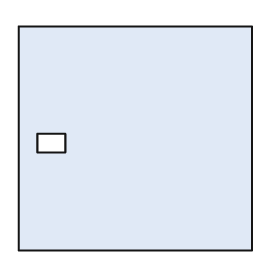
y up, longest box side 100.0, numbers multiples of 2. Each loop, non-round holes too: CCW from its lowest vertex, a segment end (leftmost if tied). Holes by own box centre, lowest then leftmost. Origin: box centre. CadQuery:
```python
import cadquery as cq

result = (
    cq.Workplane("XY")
    .moveTo(-50.0, -48.0)
    .lineTo(50.0, -48.0)
    .lineTo(50.0, 48.0)
    .lineTo(-50.0, 48.0)
    .close()
    .moveTo(-42.0, -6.0)
    .lineTo(-30.0, -6.0)
    .lineTo(-30.0, 2.0)
    .lineTo(-42.0, 2.0)
    .close()
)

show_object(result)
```